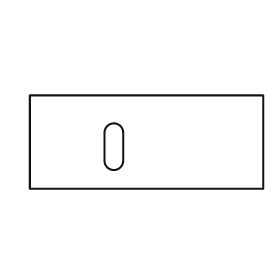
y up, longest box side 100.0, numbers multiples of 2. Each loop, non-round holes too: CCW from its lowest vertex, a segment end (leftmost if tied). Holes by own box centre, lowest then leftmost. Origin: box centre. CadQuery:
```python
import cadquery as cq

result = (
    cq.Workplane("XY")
    .moveTo(-50.0, -20.0)
    .lineTo(50.0, -20.0)
    .lineTo(50.0, 20.0)
    .lineTo(-50.0, 20.0)
    .close()
    .moveTo(-18.0, -8.0)
    .threePointArc((-14.0, -12.0), (-10.0, -8.0))
    .lineTo(-10.0, 4.0)
    .threePointArc((-14.0, 8.0), (-18.0, 4.0))
    .close()
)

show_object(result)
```